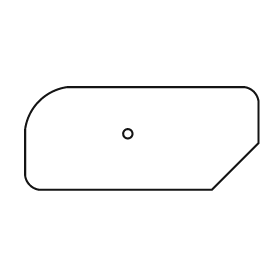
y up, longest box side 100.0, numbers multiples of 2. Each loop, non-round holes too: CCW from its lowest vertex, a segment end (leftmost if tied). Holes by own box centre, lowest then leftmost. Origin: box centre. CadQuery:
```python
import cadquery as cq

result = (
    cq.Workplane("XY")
    .moveTo(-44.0, -22.0)
    .lineTo(30.0, -22.0)
    .lineTo(50.0, -2.0)
    .lineTo(50.0, 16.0)
    .threePointArc((48.0, 20.0), (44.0, 22.0))
    .lineTo(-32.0, 22.0)
    .threePointArc((-44.0, 16.0), (-50.0, 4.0))
    .lineTo(-50.0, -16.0)
    .threePointArc((-48.0, -20.0), (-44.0, -22.0))
    .close()
    .moveTo(-6.0, 2.0)
    .circle(2.0)
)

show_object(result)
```